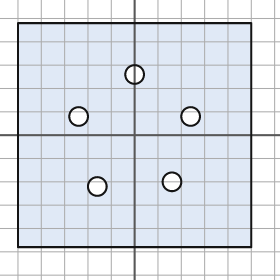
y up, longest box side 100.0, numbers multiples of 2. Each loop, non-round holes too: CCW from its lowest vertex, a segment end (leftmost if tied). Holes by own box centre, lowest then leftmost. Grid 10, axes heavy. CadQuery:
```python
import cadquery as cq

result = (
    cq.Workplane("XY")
    .moveTo(-50.0, -48.0)
    .lineTo(50.0, -48.0)
    .lineTo(50.0, 48.0)
    .lineTo(-50.0, 48.0)
    .close()
    .moveTo(-16.0, -22.0)
    .circle(4.0)
    .moveTo(16.0, -20.0)
    .circle(4.0)
    .moveTo(-24.0, 8.0)
    .circle(4.0)
    .moveTo(24.0, 8.0)
    .circle(4.0)
    .moveTo(0.0, 26.0)
    .circle(4.0)
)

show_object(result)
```